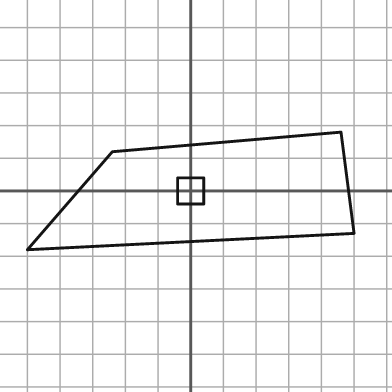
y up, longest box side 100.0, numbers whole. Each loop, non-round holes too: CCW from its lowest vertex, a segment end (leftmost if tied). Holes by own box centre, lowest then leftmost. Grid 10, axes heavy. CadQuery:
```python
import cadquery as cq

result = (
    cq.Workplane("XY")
    .moveTo(-50.0, -18.0)
    .lineTo(50.0, -13.0)
    .lineTo(46.0, 18.0)
    .lineTo(-24.0, 12.0)
    .close()
    .moveTo(-4.0, -4.0)
    .lineTo(4.0, -4.0)
    .lineTo(4.0, 4.0)
    .lineTo(-4.0, 4.0)
    .close()
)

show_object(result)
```